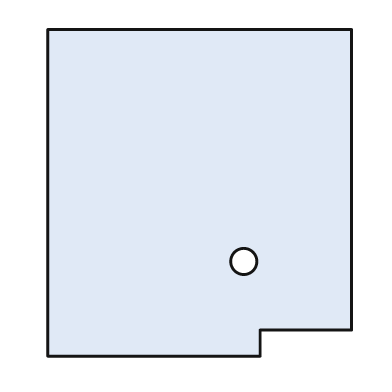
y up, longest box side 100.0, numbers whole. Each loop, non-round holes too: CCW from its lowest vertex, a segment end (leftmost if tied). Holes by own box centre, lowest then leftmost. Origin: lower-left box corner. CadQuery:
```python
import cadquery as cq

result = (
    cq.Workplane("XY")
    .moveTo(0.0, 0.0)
    .lineTo(65.0, 0.0)
    .lineTo(65.0, 8.0)
    .lineTo(93.0, 8.0)
    .lineTo(93.0, 100.0)
    .lineTo(0.0, 100.0)
    .close()
    .moveTo(60.0, 29.0)
    .circle(4.0)
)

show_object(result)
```